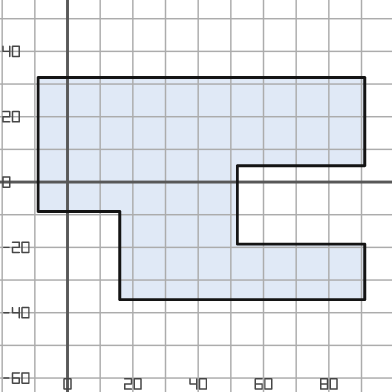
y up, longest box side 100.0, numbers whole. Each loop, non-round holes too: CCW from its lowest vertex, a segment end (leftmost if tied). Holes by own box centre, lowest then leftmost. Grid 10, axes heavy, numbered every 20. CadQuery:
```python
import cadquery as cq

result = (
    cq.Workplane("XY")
    .moveTo(16.0, -36.0)
    .lineTo(91.0, -36.0)
    .lineTo(91.0, -19.0)
    .lineTo(52.0, -19.0)
    .lineTo(52.0, 5.0)
    .lineTo(91.0, 5.0)
    .lineTo(91.0, 32.0)
    .lineTo(-9.0, 32.0)
    .lineTo(-9.0, -9.0)
    .lineTo(16.0, -9.0)
    .close()
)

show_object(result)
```